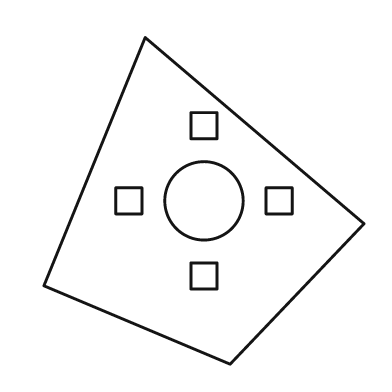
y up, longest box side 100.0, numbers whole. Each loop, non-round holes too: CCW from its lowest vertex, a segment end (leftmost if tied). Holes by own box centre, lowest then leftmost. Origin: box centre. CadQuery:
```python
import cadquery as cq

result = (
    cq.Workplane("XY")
    .moveTo(8.0, -50.0)
    .lineTo(49.0, -7.0)
    .lineTo(-18.0, 50.0)
    .lineTo(-49.0, -26.0)
    .close()
    .moveTo(-4.0, -27.0)
    .lineTo(4.0, -27.0)
    .lineTo(4.0, -19.0)
    .lineTo(-4.0, -19.0)
    .close()
    .moveTo(-27.0, -4.0)
    .lineTo(-19.0, -4.0)
    .lineTo(-19.0, 4.0)
    .lineTo(-27.0, 4.0)
    .close()
    .moveTo(0.0, 0.0)
    .circle(12.0)
    .moveTo(19.0, -4.0)
    .lineTo(27.0, -4.0)
    .lineTo(27.0, 4.0)
    .lineTo(19.0, 4.0)
    .close()
    .moveTo(-4.0, 19.0)
    .lineTo(4.0, 19.0)
    .lineTo(4.0, 27.0)
    .lineTo(-4.0, 27.0)
    .close()
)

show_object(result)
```